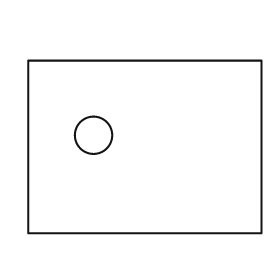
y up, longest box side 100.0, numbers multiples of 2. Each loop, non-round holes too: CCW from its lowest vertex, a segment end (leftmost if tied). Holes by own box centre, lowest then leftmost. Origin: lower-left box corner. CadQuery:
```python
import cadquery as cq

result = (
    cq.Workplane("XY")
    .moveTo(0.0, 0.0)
    .lineTo(100.0, 0.0)
    .lineTo(100.0, 74.0)
    .lineTo(0.0, 74.0)
    .close()
    .moveTo(28.0, 42.0)
    .circle(8.0)
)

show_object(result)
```